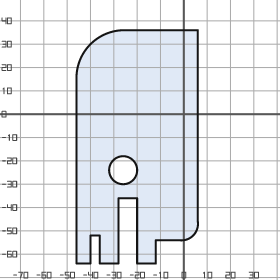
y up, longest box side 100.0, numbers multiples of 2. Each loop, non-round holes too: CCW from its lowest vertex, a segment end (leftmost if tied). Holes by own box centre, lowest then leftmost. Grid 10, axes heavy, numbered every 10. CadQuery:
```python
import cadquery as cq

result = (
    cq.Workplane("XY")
    .moveTo(-46.0, -64.0)
    .lineTo(-40.0, -64.0)
    .lineTo(-40.0, -52.0)
    .lineTo(-36.0, -52.0)
    .lineTo(-36.0, -64.0)
    .lineTo(-28.0, -64.0)
    .lineTo(-28.0, -36.0)
    .lineTo(-20.0, -36.0)
    .lineTo(-20.0, -64.0)
    .lineTo(-12.0, -64.0)
    .lineTo(-12.0, -54.0)
    .lineTo(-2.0, -54.0)
    .threePointArc((4.0, -52.0), (6.0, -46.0))
    .lineTo(6.0, 36.0)
    .lineTo(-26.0, 36.0)
    .threePointArc((-40.0, 30.0), (-46.0, 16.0))
    .close()
    .moveTo(-26.0, -24.0)
    .circle(6.0)
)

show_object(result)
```